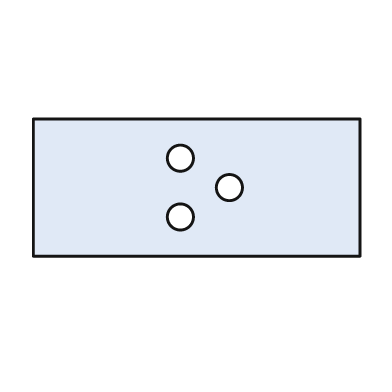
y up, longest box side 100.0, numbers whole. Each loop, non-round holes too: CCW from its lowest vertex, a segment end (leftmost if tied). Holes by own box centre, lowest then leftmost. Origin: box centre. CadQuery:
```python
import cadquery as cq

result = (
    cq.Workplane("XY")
    .moveTo(-50.0, -21.0)
    .lineTo(50.0, -21.0)
    .lineTo(50.0, 21.0)
    .lineTo(-50.0, 21.0)
    .close()
    .moveTo(-5.0, -9.0)
    .circle(4.0)
    .moveTo(10.0, 0.0)
    .circle(4.0)
    .moveTo(-5.0, 9.0)
    .circle(4.0)
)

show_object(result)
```